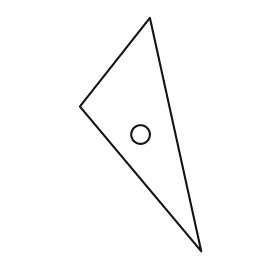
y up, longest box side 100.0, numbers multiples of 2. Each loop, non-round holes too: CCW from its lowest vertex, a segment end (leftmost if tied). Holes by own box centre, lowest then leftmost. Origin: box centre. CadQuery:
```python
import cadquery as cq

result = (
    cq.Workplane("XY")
    .moveTo(26.0, -50.0)
    .lineTo(4.0, 50.0)
    .lineTo(-26.0, 12.0)
    .close()
    .moveTo(0.0, 0.0)
    .circle(4.0)
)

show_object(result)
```